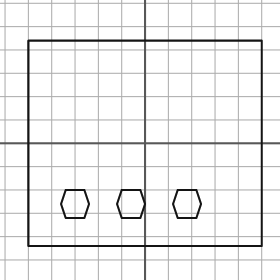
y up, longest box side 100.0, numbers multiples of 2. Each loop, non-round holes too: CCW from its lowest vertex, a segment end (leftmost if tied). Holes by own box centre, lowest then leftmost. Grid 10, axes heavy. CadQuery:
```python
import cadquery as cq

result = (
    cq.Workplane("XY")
    .moveTo(-50.0, -44.0)
    .lineTo(50.0, -44.0)
    .lineTo(50.0, 44.0)
    .lineTo(-50.0, 44.0)
    .close()
    .moveTo(-34.0, -32.0)
    .lineTo(-26.0, -32.0)
    .lineTo(-24.0, -26.0)
    .lineTo(-26.0, -20.0)
    .lineTo(-34.0, -20.0)
    .lineTo(-36.0, -26.0)
    .close()
    .moveTo(-10.0, -32.0)
    .lineTo(-2.0, -32.0)
    .lineTo(0.0, -26.0)
    .lineTo(-2.0, -20.0)
    .lineTo(-10.0, -20.0)
    .lineTo(-12.0, -26.0)
    .close()
    .moveTo(14.0, -32.0)
    .lineTo(22.0, -32.0)
    .lineTo(24.0, -26.0)
    .lineTo(22.0, -20.0)
    .lineTo(14.0, -20.0)
    .lineTo(12.0, -26.0)
    .close()
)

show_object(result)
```